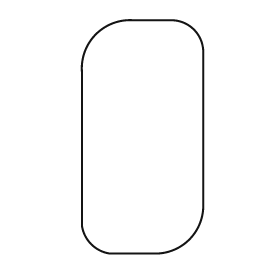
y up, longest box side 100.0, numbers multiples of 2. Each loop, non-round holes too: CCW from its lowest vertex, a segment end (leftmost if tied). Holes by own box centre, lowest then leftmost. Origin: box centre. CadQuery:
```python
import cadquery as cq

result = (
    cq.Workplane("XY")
    .moveTo(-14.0, -50.0)
    .lineTo(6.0, -50.0)
    .threePointArc((20.0, -44.0), (26.0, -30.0))
    .lineTo(26.0, 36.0)
    .threePointArc((22.0, 46.0), (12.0, 50.0))
    .lineTo(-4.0, 50.0)
    .threePointArc((-20.0, 44.0), (-26.0, 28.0))
    .lineTo(-26.0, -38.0)
    .threePointArc((-22.0, -46.0), (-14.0, -50.0))
    .close()
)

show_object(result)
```